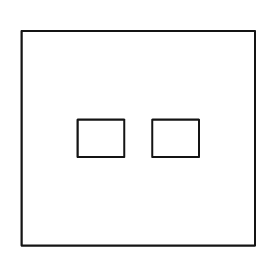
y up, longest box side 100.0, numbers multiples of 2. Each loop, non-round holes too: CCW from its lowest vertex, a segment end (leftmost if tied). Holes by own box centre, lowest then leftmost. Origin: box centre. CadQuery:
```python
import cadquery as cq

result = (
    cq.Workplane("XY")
    .moveTo(-50.0, -46.0)
    .lineTo(50.0, -46.0)
    .lineTo(50.0, 46.0)
    .lineTo(-50.0, 46.0)
    .close()
    .moveTo(-26.0, -8.0)
    .lineTo(-6.0, -8.0)
    .lineTo(-6.0, 8.0)
    .lineTo(-26.0, 8.0)
    .close()
    .moveTo(6.0, -8.0)
    .lineTo(26.0, -8.0)
    .lineTo(26.0, 8.0)
    .lineTo(6.0, 8.0)
    .close()
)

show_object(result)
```